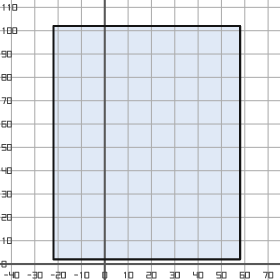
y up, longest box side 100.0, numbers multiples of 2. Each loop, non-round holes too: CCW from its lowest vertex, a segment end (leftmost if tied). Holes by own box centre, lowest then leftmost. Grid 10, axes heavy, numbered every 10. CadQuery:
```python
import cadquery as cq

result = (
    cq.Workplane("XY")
    .moveTo(-22.0, 2.0)
    .lineTo(58.0, 2.0)
    .lineTo(58.0, 102.0)
    .lineTo(-22.0, 102.0)
    .close()
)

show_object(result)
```